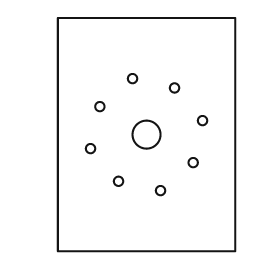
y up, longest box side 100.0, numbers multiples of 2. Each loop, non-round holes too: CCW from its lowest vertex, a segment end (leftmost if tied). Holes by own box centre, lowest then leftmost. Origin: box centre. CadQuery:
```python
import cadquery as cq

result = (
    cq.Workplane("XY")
    .moveTo(-38.0, -50.0)
    .lineTo(38.0, -50.0)
    .lineTo(38.0, 50.0)
    .lineTo(-38.0, 50.0)
    .close()
    .moveTo(6.0, -24.0)
    .circle(2.0)
    .moveTo(-12.0, -20.0)
    .circle(2.0)
    .moveTo(20.0, -12.0)
    .circle(2.0)
    .moveTo(-24.0, -6.0)
    .circle(2.0)
    .moveTo(0.0, 0.0)
    .circle(6.0)
    .moveTo(24.0, 6.0)
    .circle(2.0)
    .moveTo(-20.0, 12.0)
    .circle(2.0)
    .moveTo(12.0, 20.0)
    .circle(2.0)
    .moveTo(-6.0, 24.0)
    .circle(2.0)
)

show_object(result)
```